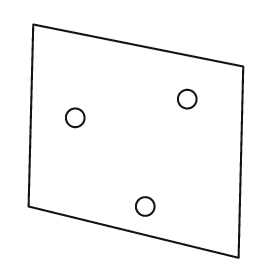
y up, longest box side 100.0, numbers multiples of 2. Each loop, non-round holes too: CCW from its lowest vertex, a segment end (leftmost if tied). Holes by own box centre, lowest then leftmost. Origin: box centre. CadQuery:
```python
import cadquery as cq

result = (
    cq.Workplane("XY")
    .moveTo(44.0, -50.0)
    .lineTo(46.0, 32.0)
    .lineTo(-44.0, 50.0)
    .lineTo(-46.0, -28.0)
    .close()
    .moveTo(4.0, -28.0)
    .circle(4.0)
    .moveTo(-26.0, 10.0)
    .circle(4.0)
    .moveTo(22.0, 18.0)
    .circle(4.0)
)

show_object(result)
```